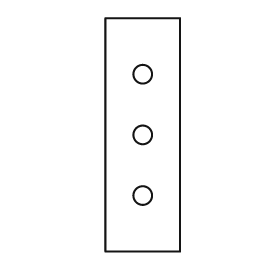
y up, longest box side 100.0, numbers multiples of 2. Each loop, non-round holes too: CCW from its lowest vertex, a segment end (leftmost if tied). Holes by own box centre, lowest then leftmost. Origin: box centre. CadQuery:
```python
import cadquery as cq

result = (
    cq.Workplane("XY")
    .moveTo(-16.0, -50.0)
    .lineTo(16.0, -50.0)
    .lineTo(16.0, 50.0)
    .lineTo(-16.0, 50.0)
    .close()
    .moveTo(0.0, -26.0)
    .circle(4.0)
    .moveTo(0.0, 0.0)
    .circle(4.0)
    .moveTo(0.0, 26.0)
    .circle(4.0)
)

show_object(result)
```